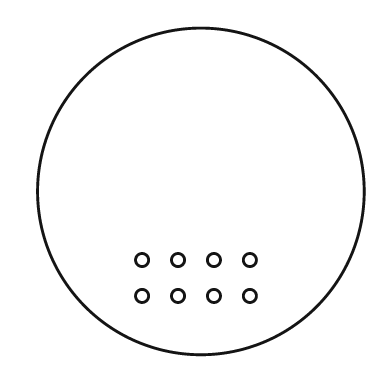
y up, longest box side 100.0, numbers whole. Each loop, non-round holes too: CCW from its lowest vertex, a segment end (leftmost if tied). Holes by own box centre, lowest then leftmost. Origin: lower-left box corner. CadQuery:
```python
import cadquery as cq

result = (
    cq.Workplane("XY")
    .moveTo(50.0, 50.0)
    .circle(50.0)
    .moveTo(32.0, 18.0)
    .circle(2.0)
    .moveTo(43.0, 18.0)
    .circle(2.0)
    .moveTo(54.0, 18.0)
    .circle(2.0)
    .moveTo(65.0, 18.0)
    .circle(2.0)
    .moveTo(32.0, 29.0)
    .circle(2.0)
    .moveTo(43.0, 29.0)
    .circle(2.0)
    .moveTo(54.0, 29.0)
    .circle(2.0)
    .moveTo(65.0, 29.0)
    .circle(2.0)
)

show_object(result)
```